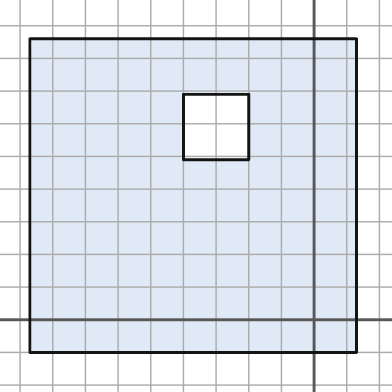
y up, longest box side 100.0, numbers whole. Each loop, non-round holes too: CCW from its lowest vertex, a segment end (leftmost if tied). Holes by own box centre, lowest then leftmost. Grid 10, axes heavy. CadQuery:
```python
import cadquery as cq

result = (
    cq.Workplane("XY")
    .moveTo(-87.0, -10.0)
    .lineTo(13.0, -10.0)
    .lineTo(13.0, 86.0)
    .lineTo(-87.0, 86.0)
    .close()
    .moveTo(-40.0, 49.0)
    .lineTo(-20.0, 49.0)
    .lineTo(-20.0, 69.0)
    .lineTo(-40.0, 69.0)
    .close()
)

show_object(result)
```